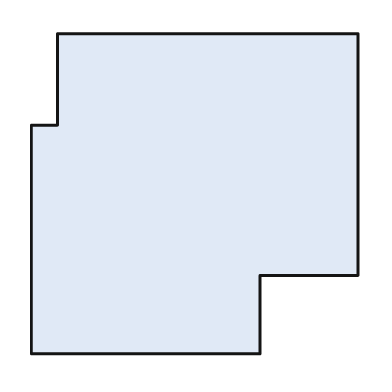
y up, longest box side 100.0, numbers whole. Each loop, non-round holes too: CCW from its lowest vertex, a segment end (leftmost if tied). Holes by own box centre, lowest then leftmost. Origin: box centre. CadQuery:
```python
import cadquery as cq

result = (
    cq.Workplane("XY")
    .moveTo(-50.0, -49.0)
    .lineTo(20.0, -49.0)
    .lineTo(20.0, -25.0)
    .lineTo(50.0, -25.0)
    .lineTo(50.0, 49.0)
    .lineTo(-42.0, 49.0)
    .lineTo(-42.0, 21.0)
    .lineTo(-50.0, 21.0)
    .close()
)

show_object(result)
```